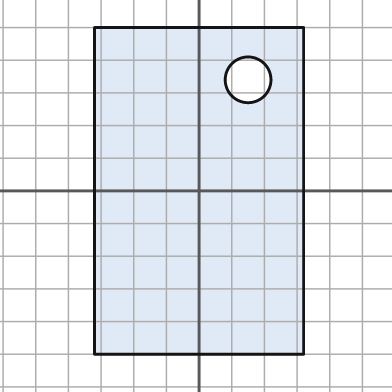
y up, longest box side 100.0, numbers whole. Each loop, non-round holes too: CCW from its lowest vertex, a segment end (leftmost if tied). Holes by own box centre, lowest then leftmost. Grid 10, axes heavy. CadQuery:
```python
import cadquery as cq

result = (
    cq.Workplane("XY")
    .moveTo(-32.0, -50.0)
    .lineTo(32.0, -50.0)
    .lineTo(32.0, 50.0)
    .lineTo(-32.0, 50.0)
    .close()
    .moveTo(15.0, 34.0)
    .circle(7.0)
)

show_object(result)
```